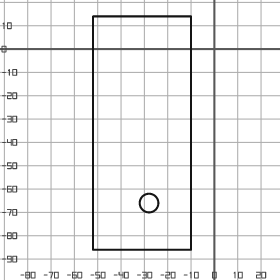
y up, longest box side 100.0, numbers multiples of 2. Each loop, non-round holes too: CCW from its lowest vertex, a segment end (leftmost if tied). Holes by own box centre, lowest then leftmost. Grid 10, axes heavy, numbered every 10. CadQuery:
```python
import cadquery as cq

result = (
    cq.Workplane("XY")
    .moveTo(-52.0, -86.0)
    .lineTo(-10.0, -86.0)
    .lineTo(-10.0, 14.0)
    .lineTo(-52.0, 14.0)
    .close()
    .moveTo(-28.0, -66.0)
    .circle(4.0)
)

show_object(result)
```